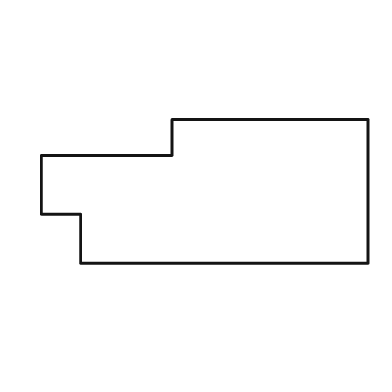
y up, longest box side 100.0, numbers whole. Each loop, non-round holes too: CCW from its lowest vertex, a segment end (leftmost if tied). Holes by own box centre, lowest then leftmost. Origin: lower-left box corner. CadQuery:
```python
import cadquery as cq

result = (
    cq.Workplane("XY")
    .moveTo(12.0, 0.0)
    .lineTo(100.0, 0.0)
    .lineTo(100.0, 44.0)
    .lineTo(40.0, 44.0)
    .lineTo(40.0, 33.0)
    .lineTo(0.0, 33.0)
    .lineTo(0.0, 15.0)
    .lineTo(12.0, 15.0)
    .close()
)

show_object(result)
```